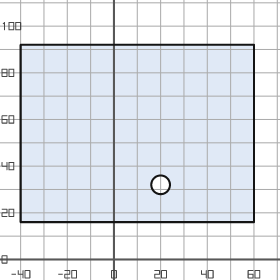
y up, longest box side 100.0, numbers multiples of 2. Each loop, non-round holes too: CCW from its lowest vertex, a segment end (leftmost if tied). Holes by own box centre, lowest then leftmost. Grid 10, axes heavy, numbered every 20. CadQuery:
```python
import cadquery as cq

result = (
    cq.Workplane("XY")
    .moveTo(-40.0, 16.0)
    .lineTo(60.0, 16.0)
    .lineTo(60.0, 92.0)
    .lineTo(-40.0, 92.0)
    .close()
    .moveTo(20.0, 32.0)
    .circle(4.0)
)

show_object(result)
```